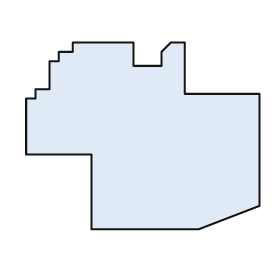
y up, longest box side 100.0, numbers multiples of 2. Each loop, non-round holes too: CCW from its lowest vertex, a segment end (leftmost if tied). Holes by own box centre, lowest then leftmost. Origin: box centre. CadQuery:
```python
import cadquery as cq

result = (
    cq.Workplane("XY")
    .moveTo(-22.0, -40.0)
    .lineTo(24.0, -40.0)
    .lineTo(50.0, -30.0)
    .lineTo(50.0, 18.0)
    .lineTo(18.0, 18.0)
    .lineTo(18.0, 40.0)
    .lineTo(12.0, 40.0)
    .lineTo(8.0, 36.0)
    .lineTo(8.0, 30.0)
    .lineTo(-4.0, 30.0)
    .lineTo(-4.0, 40.0)
    .lineTo(-30.0, 40.0)
    .lineTo(-30.0, 36.0)
    .lineTo(-36.0, 36.0)
    .lineTo(-36.0, 32.0)
    .lineTo(-40.0, 32.0)
    .lineTo(-40.0, 20.0)
    .lineTo(-46.0, 20.0)
    .lineTo(-46.0, 16.0)
    .lineTo(-50.0, 16.0)
    .lineTo(-50.0, -8.0)
    .lineTo(-22.0, -8.0)
    .close()
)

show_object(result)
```